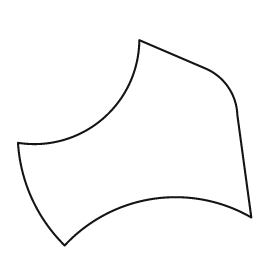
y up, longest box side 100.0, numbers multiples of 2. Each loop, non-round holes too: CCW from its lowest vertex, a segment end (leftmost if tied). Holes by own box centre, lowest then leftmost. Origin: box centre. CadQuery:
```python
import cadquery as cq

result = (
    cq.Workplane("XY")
    .moveTo(-30.0, -44.0)
    .threePointArc((8.0, -24.0), (50.0, -32.0))
    .lineTo(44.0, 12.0)
    .threePointArc((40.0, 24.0), (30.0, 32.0))
    .lineTo(2.0, 44.0)
    .threePointArc((-14.0, 10.0), (-50.0, 0.0))
    .threePointArc((-44.0, -24.0), (-30.0, -44.0))
    .close()
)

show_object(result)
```